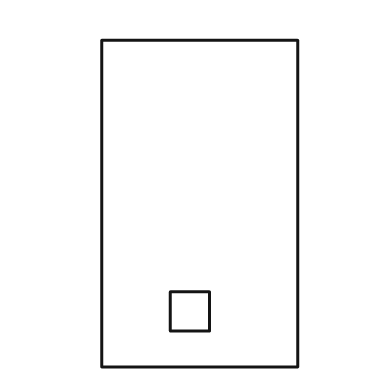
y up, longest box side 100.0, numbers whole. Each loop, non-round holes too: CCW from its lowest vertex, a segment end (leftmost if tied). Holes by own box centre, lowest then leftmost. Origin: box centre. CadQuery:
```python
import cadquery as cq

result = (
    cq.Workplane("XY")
    .moveTo(-30.0, -50.0)
    .lineTo(30.0, -50.0)
    .lineTo(30.0, 50.0)
    .lineTo(-30.0, 50.0)
    .close()
    .moveTo(-9.0, -39.0)
    .lineTo(3.0, -39.0)
    .lineTo(3.0, -27.0)
    .lineTo(-9.0, -27.0)
    .close()
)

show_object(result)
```